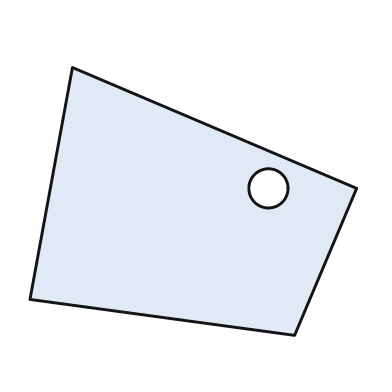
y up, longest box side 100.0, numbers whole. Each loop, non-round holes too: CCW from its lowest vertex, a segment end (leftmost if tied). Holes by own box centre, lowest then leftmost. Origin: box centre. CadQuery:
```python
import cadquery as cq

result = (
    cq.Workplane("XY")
    .moveTo(31.0, -41.0)
    .lineTo(50.0, 4.0)
    .lineTo(-37.0, 41.0)
    .lineTo(-50.0, -30.0)
    .close()
    .moveTo(23.0, 4.0)
    .circle(6.0)
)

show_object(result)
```